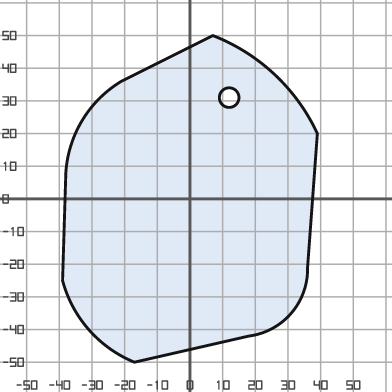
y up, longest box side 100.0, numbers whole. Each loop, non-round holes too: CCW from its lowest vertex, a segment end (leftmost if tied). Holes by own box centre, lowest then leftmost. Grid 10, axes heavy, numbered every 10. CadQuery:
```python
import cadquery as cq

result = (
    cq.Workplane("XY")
    .moveTo(-17.0, -50.0)
    .lineTo(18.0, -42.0)
    .threePointArc((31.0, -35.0), (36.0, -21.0))
    .lineTo(39.0, 20.0)
    .threePointArc((26.0, 38.0), (7.0, 50.0))
    .lineTo(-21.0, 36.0)
    .threePointArc((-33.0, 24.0), (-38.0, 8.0))
    .lineTo(-39.0, -25.0)
    .threePointArc((-31.0, -40.0), (-17.0, -50.0))
    .close()
    .moveTo(12.0, 31.0)
    .circle(3.0)
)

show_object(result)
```